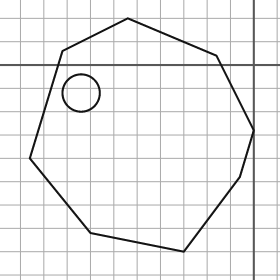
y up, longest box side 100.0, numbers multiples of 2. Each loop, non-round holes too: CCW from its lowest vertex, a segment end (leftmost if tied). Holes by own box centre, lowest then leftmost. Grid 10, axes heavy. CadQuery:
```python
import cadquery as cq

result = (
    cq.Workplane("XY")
    .moveTo(-30.0, -80.0)
    .lineTo(-6.0, -48.0)
    .lineTo(0.0, -28.0)
    .lineTo(-16.0, 4.0)
    .lineTo(-54.0, 20.0)
    .lineTo(-82.0, 6.0)
    .lineTo(-96.0, -40.0)
    .lineTo(-70.0, -72.0)
    .close()
    .moveTo(-74.0, -12.0)
    .circle(8.0)
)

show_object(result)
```